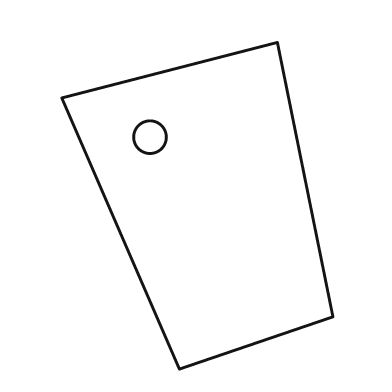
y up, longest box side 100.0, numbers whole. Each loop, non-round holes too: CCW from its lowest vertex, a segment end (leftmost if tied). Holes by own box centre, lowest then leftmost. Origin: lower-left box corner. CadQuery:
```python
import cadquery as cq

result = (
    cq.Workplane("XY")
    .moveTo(36.0, 0.0)
    .lineTo(83.0, 16.0)
    .lineTo(66.0, 100.0)
    .lineTo(0.0, 83.0)
    .close()
    .moveTo(27.0, 71.0)
    .circle(5.0)
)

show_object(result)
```